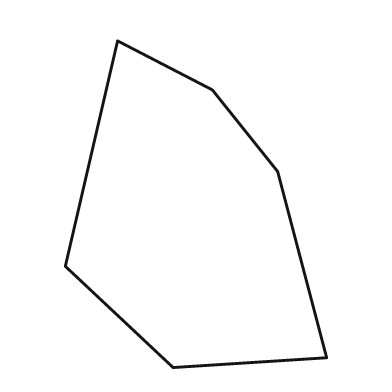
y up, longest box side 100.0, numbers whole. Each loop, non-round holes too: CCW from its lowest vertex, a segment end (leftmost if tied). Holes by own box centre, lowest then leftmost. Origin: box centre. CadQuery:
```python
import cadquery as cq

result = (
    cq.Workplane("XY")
    .moveTo(-7.0, -50.0)
    .lineTo(40.0, -47.0)
    .lineTo(25.0, 10.0)
    .lineTo(5.0, 35.0)
    .lineTo(-24.0, 50.0)
    .lineTo(-40.0, -19.0)
    .close()
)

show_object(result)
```